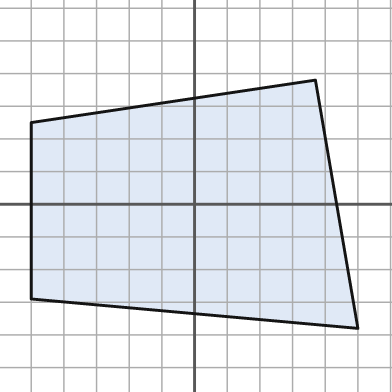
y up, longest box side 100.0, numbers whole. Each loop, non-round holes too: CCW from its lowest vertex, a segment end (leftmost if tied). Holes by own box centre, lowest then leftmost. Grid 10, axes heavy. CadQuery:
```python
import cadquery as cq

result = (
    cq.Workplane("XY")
    .moveTo(50.0, -38.0)
    .lineTo(37.0, 38.0)
    .lineTo(-50.0, 25.0)
    .lineTo(-50.0, -29.0)
    .close()
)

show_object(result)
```